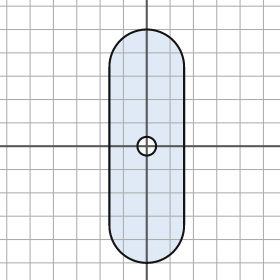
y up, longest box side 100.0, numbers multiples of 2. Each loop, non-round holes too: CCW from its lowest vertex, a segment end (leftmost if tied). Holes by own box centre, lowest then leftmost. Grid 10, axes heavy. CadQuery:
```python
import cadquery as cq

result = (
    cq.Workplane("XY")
    .moveTo(-16.0, -34.0)
    .threePointArc((0.0, -50.0), (16.0, -34.0))
    .lineTo(16.0, 34.0)
    .threePointArc((0.0, 50.0), (-16.0, 34.0))
    .close()
    .moveTo(0.0, 0.0)
    .circle(4.0)
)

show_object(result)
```